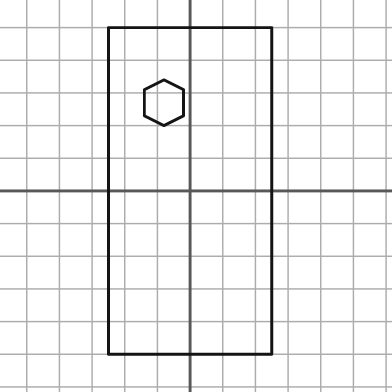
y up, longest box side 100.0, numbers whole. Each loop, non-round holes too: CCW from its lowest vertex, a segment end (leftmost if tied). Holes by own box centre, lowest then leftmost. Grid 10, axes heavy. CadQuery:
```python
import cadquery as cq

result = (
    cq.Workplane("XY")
    .moveTo(-25.0, -50.0)
    .lineTo(25.0, -50.0)
    .lineTo(25.0, 50.0)
    .lineTo(-25.0, 50.0)
    .close()
    .moveTo(-8.0, 20.0)
    .lineTo(-2.0, 23.0)
    .lineTo(-2.0, 31.0)
    .lineTo(-8.0, 34.0)
    .lineTo(-14.0, 31.0)
    .lineTo(-14.0, 23.0)
    .close()
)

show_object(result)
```